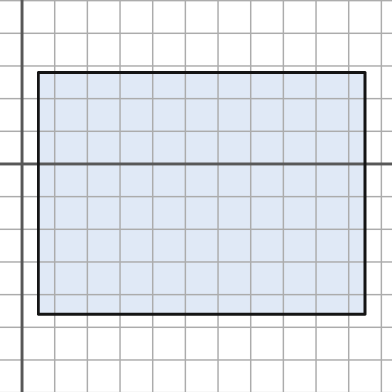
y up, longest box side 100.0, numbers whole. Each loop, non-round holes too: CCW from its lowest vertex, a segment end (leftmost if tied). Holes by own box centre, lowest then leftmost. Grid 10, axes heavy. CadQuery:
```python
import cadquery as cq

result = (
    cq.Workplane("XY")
    .moveTo(5.0, -46.0)
    .lineTo(105.0, -46.0)
    .lineTo(105.0, 28.0)
    .lineTo(5.0, 28.0)
    .close()
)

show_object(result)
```